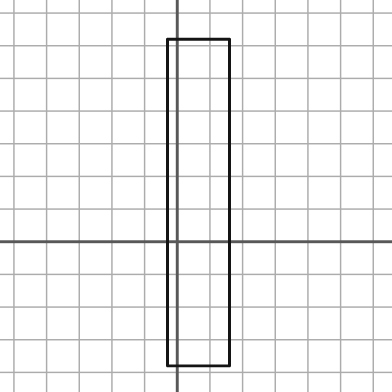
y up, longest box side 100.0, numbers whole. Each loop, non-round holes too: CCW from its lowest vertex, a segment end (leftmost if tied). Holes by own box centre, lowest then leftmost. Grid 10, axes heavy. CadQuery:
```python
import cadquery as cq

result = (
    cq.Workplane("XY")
    .moveTo(-3.0, -38.0)
    .lineTo(16.0, -38.0)
    .lineTo(16.0, 62.0)
    .lineTo(-3.0, 62.0)
    .close()
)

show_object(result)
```